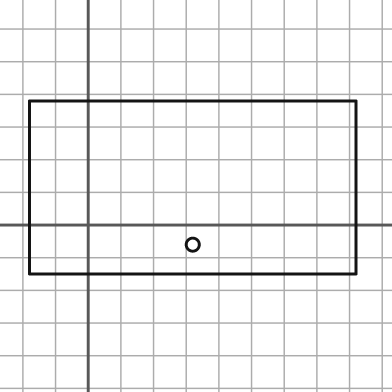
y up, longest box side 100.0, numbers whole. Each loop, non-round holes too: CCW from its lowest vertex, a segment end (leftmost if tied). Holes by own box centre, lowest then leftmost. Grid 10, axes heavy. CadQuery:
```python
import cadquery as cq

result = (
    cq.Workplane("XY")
    .moveTo(-18.0, -15.0)
    .lineTo(82.0, -15.0)
    .lineTo(82.0, 38.0)
    .lineTo(-18.0, 38.0)
    .close()
    .moveTo(32.0, -6.0)
    .circle(2.0)
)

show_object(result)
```